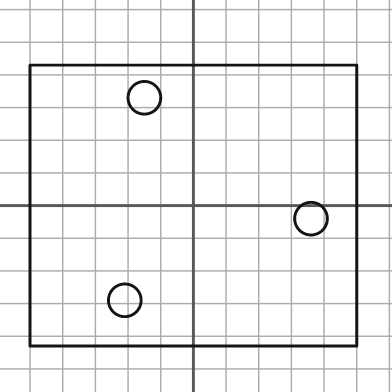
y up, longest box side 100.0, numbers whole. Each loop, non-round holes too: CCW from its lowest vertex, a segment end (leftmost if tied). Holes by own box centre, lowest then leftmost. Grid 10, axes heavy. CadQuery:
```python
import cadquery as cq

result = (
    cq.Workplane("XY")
    .moveTo(-50.0, -43.0)
    .lineTo(50.0, -43.0)
    .lineTo(50.0, 43.0)
    .lineTo(-50.0, 43.0)
    .close()
    .moveTo(-21.0, -29.0)
    .circle(5.0)
    .moveTo(36.0, -4.0)
    .circle(5.0)
    .moveTo(-15.0, 33.0)
    .circle(5.0)
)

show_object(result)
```